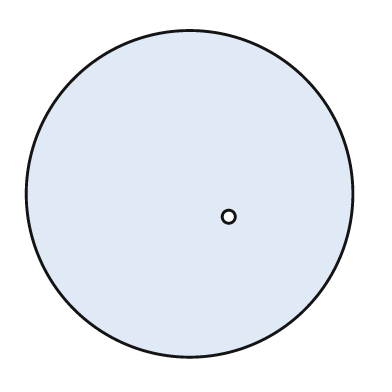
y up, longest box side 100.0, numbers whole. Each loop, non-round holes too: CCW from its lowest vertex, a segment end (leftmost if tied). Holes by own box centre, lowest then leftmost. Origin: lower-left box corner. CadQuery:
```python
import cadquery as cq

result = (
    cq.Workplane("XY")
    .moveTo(50.0, 50.0)
    .circle(50.0)
    .moveTo(62.0, 43.0)
    .circle(2.0)
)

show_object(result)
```